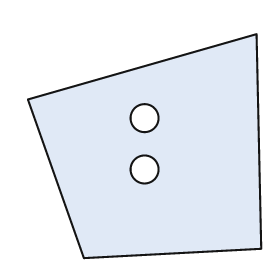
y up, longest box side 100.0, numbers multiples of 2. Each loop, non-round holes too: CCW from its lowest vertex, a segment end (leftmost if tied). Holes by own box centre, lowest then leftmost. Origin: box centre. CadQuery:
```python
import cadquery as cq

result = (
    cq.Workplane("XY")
    .moveTo(-26.0, -48.0)
    .lineTo(50.0, -44.0)
    .lineTo(48.0, 48.0)
    .lineTo(-50.0, 20.0)
    .close()
    .moveTo(0.0, -10.0)
    .circle(6.0)
    .moveTo(0.0, 12.0)
    .circle(6.0)
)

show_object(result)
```